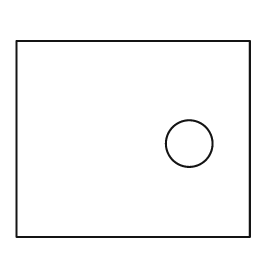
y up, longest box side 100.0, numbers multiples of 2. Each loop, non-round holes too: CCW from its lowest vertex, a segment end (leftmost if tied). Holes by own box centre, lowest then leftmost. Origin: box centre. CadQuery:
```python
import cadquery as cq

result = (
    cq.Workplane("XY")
    .moveTo(-50.0, -42.0)
    .lineTo(50.0, -42.0)
    .lineTo(50.0, 42.0)
    .lineTo(-50.0, 42.0)
    .close()
    .moveTo(24.0, -2.0)
    .circle(10.0)
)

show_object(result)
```